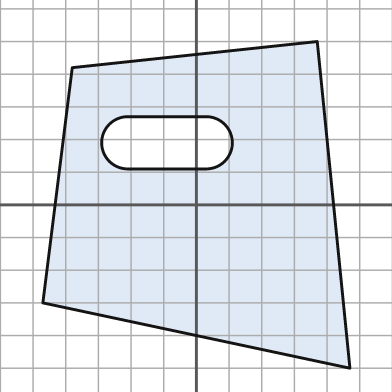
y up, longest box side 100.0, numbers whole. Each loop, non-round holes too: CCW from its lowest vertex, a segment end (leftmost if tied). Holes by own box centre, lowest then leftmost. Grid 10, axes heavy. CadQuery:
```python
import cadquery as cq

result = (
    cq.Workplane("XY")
    .moveTo(47.0, -50.0)
    .lineTo(37.0, 50.0)
    .lineTo(-38.0, 42.0)
    .lineTo(-47.0, -30.0)
    .close()
    .moveTo(-21.0, 11.0)
    .lineTo(3.0, 11.0)
    .threePointArc((11.0, 19.0), (3.0, 27.0))
    .lineTo(-21.0, 27.0)
    .threePointArc((-29.0, 19.0), (-21.0, 11.0))
    .close()
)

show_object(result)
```